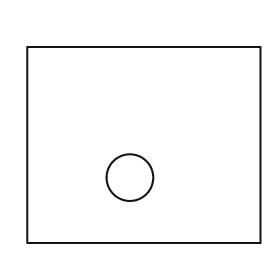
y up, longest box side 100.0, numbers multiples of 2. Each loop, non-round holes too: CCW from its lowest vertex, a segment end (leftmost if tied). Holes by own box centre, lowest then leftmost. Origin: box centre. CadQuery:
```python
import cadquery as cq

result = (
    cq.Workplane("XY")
    .moveTo(-50.0, -42.0)
    .lineTo(50.0, -42.0)
    .lineTo(50.0, 42.0)
    .lineTo(-50.0, 42.0)
    .close()
    .moveTo(-6.0, -14.0)
    .circle(10.0)
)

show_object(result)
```